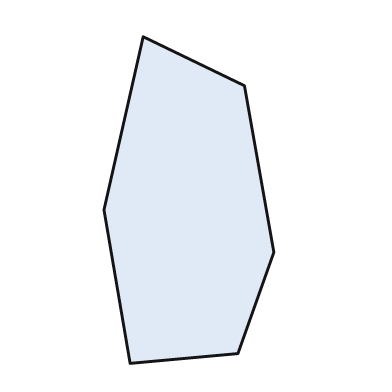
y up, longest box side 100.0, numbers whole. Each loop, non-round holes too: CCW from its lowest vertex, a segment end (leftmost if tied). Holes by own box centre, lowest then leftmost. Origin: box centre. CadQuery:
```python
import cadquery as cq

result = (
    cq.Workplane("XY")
    .moveTo(-18.0, -50.0)
    .lineTo(15.0, -47.0)
    .lineTo(26.0, -16.0)
    .lineTo(17.0, 35.0)
    .lineTo(-14.0, 50.0)
    .lineTo(-26.0, -3.0)
    .close()
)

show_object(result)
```